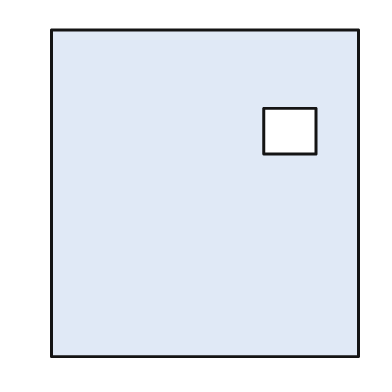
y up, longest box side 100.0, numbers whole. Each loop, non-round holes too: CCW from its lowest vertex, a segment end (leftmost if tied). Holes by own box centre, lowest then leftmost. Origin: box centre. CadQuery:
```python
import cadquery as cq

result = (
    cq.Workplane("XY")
    .moveTo(-47.0, -50.0)
    .lineTo(47.0, -50.0)
    .lineTo(47.0, 50.0)
    .lineTo(-47.0, 50.0)
    .close()
    .moveTo(18.0, 12.0)
    .lineTo(34.0, 12.0)
    .lineTo(34.0, 26.0)
    .lineTo(18.0, 26.0)
    .close()
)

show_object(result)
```